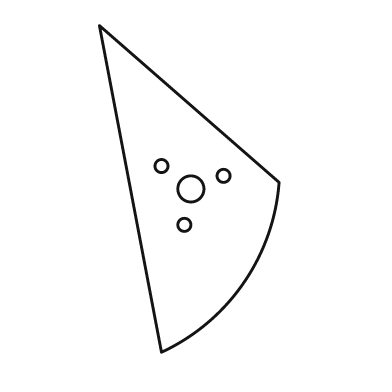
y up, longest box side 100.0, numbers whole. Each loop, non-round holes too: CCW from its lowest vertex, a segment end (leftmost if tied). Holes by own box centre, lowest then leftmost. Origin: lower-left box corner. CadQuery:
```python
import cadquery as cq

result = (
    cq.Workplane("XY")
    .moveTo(19.0, 0.0)
    .threePointArc((44.0, 21.0), (55.0, 52.0))
    .lineTo(0.0, 100.0)
    .close()
    .moveTo(26.0, 39.0)
    .circle(2.0)
    .moveTo(28.0, 50.0)
    .circle(4.0)
    .moveTo(38.0, 54.0)
    .circle(2.0)
    .moveTo(19.0, 57.0)
    .circle(2.0)
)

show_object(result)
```